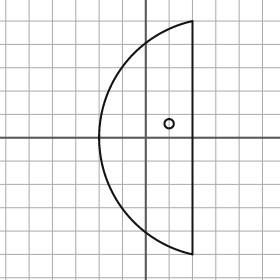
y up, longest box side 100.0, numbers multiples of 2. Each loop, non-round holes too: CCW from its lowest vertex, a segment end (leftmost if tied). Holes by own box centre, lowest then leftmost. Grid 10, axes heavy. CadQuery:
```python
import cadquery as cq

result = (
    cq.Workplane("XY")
    .moveTo(20.0, -50.0)
    .lineTo(20.0, 50.0)
    .threePointArc((-20.0, 0.0), (20.0, -50.0))
    .close()
    .moveTo(10.0, 6.0)
    .circle(2.0)
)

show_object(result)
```